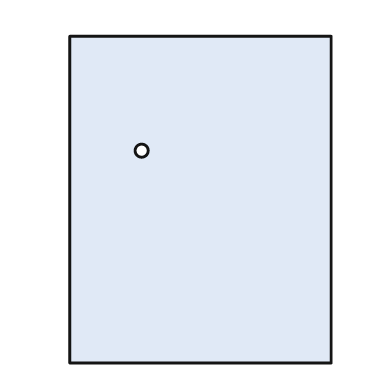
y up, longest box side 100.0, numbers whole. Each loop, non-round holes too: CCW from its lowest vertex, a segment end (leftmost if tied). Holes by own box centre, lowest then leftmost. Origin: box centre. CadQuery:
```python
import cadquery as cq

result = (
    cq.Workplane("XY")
    .moveTo(-40.0, -50.0)
    .lineTo(40.0, -50.0)
    .lineTo(40.0, 50.0)
    .lineTo(-40.0, 50.0)
    .close()
    .moveTo(-18.0, 15.0)
    .circle(2.0)
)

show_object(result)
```